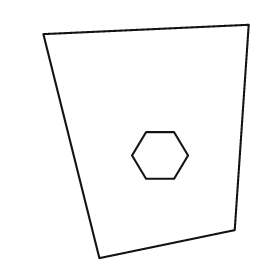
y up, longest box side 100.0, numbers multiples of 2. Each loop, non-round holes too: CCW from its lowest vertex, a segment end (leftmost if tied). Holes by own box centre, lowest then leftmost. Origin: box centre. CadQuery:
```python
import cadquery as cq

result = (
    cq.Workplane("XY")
    .moveTo(-20.0, -50.0)
    .lineTo(38.0, -38.0)
    .lineTo(44.0, 50.0)
    .lineTo(-44.0, 46.0)
    .close()
    .moveTo(0.0, -16.0)
    .lineTo(12.0, -16.0)
    .lineTo(18.0, -6.0)
    .lineTo(12.0, 4.0)
    .lineTo(0.0, 4.0)
    .lineTo(-6.0, -6.0)
    .close()
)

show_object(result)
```